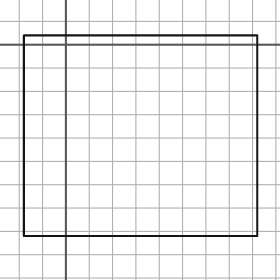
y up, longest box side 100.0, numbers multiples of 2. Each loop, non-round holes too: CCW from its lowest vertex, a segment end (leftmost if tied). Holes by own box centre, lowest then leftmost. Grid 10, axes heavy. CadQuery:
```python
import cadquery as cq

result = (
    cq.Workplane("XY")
    .moveTo(-18.0, -82.0)
    .lineTo(82.0, -82.0)
    .lineTo(82.0, 4.0)
    .lineTo(-18.0, 4.0)
    .close()
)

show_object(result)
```